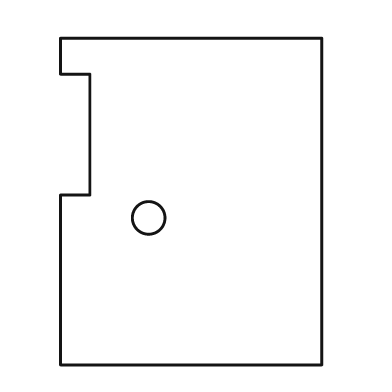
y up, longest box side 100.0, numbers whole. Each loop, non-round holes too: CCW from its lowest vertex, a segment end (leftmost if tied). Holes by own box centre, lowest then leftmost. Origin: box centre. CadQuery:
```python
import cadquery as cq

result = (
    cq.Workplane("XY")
    .moveTo(-40.0, -50.0)
    .lineTo(40.0, -50.0)
    .lineTo(40.0, 50.0)
    .lineTo(-40.0, 50.0)
    .lineTo(-40.0, 39.0)
    .lineTo(-31.0, 39.0)
    .lineTo(-31.0, 2.0)
    .lineTo(-40.0, 2.0)
    .close()
    .moveTo(-13.0, -5.0)
    .circle(5.0)
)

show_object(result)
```